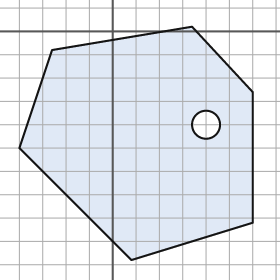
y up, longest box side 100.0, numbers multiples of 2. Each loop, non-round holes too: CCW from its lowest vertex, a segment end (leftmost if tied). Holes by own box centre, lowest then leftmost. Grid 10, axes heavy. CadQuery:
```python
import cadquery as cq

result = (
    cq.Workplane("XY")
    .moveTo(8.0, -98.0)
    .lineTo(60.0, -82.0)
    .lineTo(60.0, -26.0)
    .lineTo(34.0, 2.0)
    .lineTo(-26.0, -8.0)
    .lineTo(-40.0, -50.0)
    .close()
    .moveTo(40.0, -40.0)
    .circle(6.0)
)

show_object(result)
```